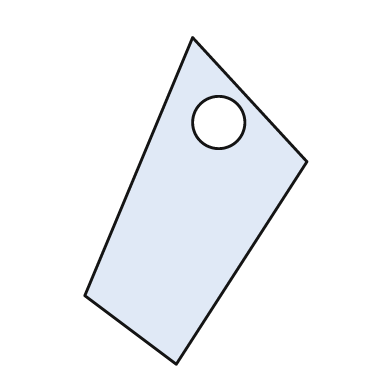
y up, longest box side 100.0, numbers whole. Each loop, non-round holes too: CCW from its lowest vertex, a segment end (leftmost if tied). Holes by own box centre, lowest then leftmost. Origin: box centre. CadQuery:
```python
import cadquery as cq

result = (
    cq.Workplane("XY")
    .moveTo(-6.0, -50.0)
    .lineTo(34.0, 12.0)
    .lineTo(-1.0, 50.0)
    .lineTo(-34.0, -29.0)
    .close()
    .moveTo(7.0, 24.0)
    .circle(8.0)
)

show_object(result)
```